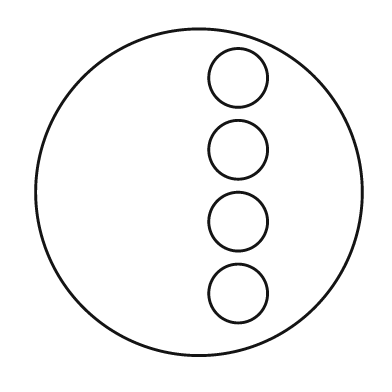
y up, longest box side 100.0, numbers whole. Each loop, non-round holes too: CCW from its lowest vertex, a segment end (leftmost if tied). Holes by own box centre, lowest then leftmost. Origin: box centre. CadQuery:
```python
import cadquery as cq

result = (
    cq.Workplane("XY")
    .moveTo(0.0, 0.0)
    .circle(50.0)
    .moveTo(12.0, -31.0)
    .circle(9.0)
    .moveTo(12.0, -9.0)
    .circle(9.0)
    .moveTo(12.0, 13.0)
    .circle(9.0)
    .moveTo(12.0, 35.0)
    .circle(9.0)
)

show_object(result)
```